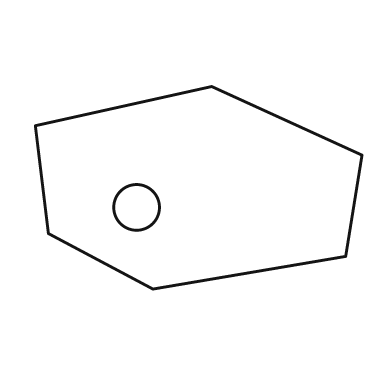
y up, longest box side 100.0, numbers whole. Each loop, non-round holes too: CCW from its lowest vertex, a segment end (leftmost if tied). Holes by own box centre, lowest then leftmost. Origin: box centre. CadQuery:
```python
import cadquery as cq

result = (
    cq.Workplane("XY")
    .moveTo(-14.0, -31.0)
    .lineTo(45.0, -21.0)
    .lineTo(50.0, 10.0)
    .lineTo(4.0, 31.0)
    .lineTo(-50.0, 19.0)
    .lineTo(-46.0, -14.0)
    .close()
    .moveTo(-19.0, -6.0)
    .circle(7.0)
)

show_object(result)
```